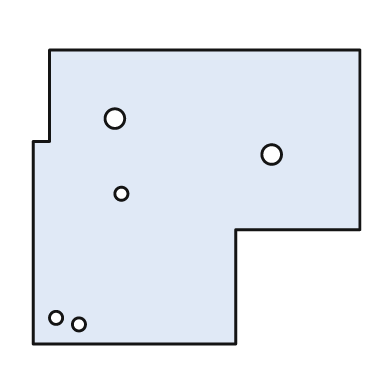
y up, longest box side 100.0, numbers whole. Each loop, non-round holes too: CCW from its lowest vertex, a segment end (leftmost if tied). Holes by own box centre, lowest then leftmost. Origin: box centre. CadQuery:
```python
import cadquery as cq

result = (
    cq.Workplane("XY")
    .moveTo(-50.0, -45.0)
    .lineTo(12.0, -45.0)
    .lineTo(12.0, -10.0)
    .lineTo(50.0, -10.0)
    .lineTo(50.0, 45.0)
    .lineTo(-45.0, 45.0)
    .lineTo(-45.0, 17.0)
    .lineTo(-50.0, 17.0)
    .close()
    .moveTo(-36.0, -39.0)
    .circle(2.0)
    .moveTo(-43.0, -37.0)
    .circle(2.0)
    .moveTo(-23.0, 1.0)
    .circle(2.0)
    .moveTo(23.0, 13.0)
    .circle(3.0)
    .moveTo(-25.0, 24.0)
    .circle(3.0)
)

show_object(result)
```